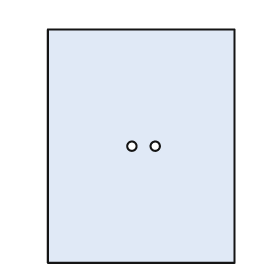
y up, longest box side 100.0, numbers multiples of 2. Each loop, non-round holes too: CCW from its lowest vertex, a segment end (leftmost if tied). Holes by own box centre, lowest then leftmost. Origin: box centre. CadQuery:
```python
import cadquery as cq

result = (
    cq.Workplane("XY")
    .moveTo(-40.0, -50.0)
    .lineTo(40.0, -50.0)
    .lineTo(40.0, 50.0)
    .lineTo(-40.0, 50.0)
    .close()
    .moveTo(-4.0, 0.0)
    .circle(2.0)
    .moveTo(6.0, 0.0)
    .circle(2.0)
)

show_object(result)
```